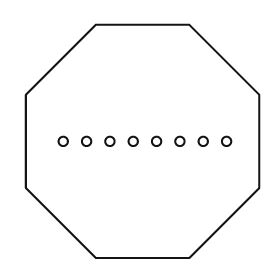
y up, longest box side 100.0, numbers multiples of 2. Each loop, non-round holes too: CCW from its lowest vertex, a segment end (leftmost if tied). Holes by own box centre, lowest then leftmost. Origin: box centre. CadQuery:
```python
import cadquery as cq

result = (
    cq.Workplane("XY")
    .moveTo(-20.0, -50.0)
    .lineTo(20.0, -50.0)
    .lineTo(50.0, -20.0)
    .lineTo(50.0, 20.0)
    .lineTo(20.0, 50.0)
    .lineTo(-20.0, 50.0)
    .lineTo(-50.0, 20.0)
    .lineTo(-50.0, -20.0)
    .close()
    .moveTo(-34.0, 0.0)
    .circle(2.0)
    .moveTo(-24.0, 0.0)
    .circle(2.0)
    .moveTo(-14.0, 0.0)
    .circle(2.0)
    .moveTo(-4.0, 0.0)
    .circle(2.0)
    .moveTo(6.0, 0.0)
    .circle(2.0)
    .moveTo(16.0, 0.0)
    .circle(2.0)
    .moveTo(26.0, 0.0)
    .circle(2.0)
    .moveTo(36.0, 0.0)
    .circle(2.0)
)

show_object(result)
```